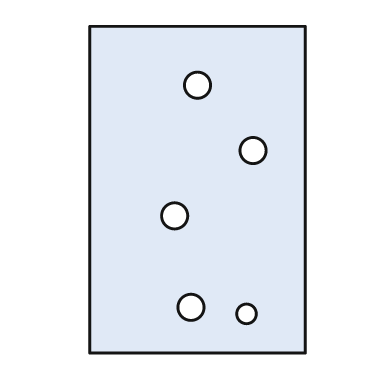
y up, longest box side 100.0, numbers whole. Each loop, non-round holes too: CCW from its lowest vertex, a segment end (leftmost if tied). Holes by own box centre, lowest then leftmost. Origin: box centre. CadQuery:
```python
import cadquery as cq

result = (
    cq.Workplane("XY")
    .moveTo(-33.0, -50.0)
    .lineTo(33.0, -50.0)
    .lineTo(33.0, 50.0)
    .lineTo(-33.0, 50.0)
    .close()
    .moveTo(15.0, -38.0)
    .circle(3.0)
    .moveTo(-2.0, -36.0)
    .circle(4.0)
    .moveTo(-7.0, -8.0)
    .circle(4.0)
    .moveTo(17.0, 12.0)
    .circle(4.0)
    .moveTo(0.0, 32.0)
    .circle(4.0)
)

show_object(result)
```